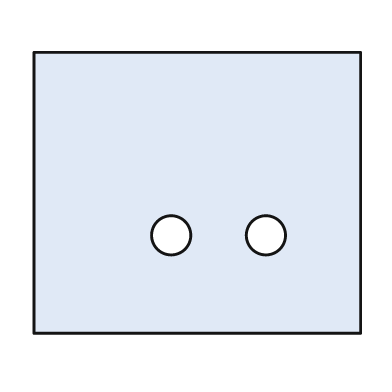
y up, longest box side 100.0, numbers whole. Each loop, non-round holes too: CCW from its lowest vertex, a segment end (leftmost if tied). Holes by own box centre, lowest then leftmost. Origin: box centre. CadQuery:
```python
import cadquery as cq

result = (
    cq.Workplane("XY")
    .moveTo(-50.0, -43.0)
    .lineTo(50.0, -43.0)
    .lineTo(50.0, 43.0)
    .lineTo(-50.0, 43.0)
    .close()
    .moveTo(-8.0, -13.0)
    .circle(6.0)
    .moveTo(21.0, -13.0)
    .circle(6.0)
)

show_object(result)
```